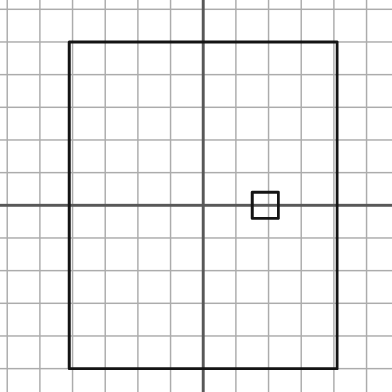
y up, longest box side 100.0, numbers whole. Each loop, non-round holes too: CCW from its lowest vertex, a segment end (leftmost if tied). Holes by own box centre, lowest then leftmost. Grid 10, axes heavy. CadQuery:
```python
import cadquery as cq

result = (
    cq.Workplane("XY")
    .moveTo(-41.0, -50.0)
    .lineTo(41.0, -50.0)
    .lineTo(41.0, 50.0)
    .lineTo(-41.0, 50.0)
    .close()
    .moveTo(15.0, -4.0)
    .lineTo(23.0, -4.0)
    .lineTo(23.0, 4.0)
    .lineTo(15.0, 4.0)
    .close()
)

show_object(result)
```